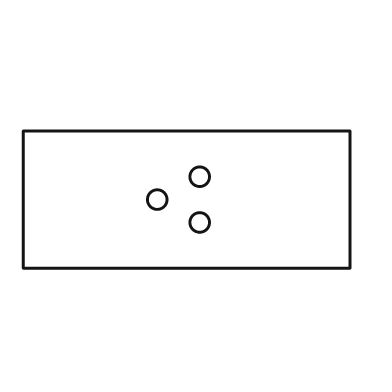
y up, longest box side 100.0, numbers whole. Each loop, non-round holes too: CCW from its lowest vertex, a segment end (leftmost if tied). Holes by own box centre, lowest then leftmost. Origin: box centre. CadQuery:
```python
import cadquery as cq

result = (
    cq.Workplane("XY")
    .moveTo(-50.0, -21.0)
    .lineTo(50.0, -21.0)
    .lineTo(50.0, 21.0)
    .lineTo(-50.0, 21.0)
    .close()
    .moveTo(4.0, -7.0)
    .circle(3.0)
    .moveTo(-9.0, 0.0)
    .circle(3.0)
    .moveTo(4.0, 7.0)
    .circle(3.0)
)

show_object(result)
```